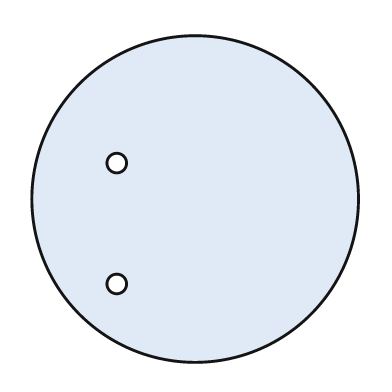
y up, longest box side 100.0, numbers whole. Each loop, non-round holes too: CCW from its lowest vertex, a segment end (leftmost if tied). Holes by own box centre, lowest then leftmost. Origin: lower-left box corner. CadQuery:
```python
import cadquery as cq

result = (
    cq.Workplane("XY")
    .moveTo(50.0, 50.0)
    .circle(50.0)
    .moveTo(26.0, 24.0)
    .circle(3.0)
    .moveTo(26.0, 61.0)
    .circle(3.0)
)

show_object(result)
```